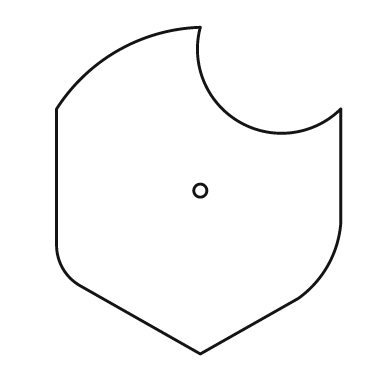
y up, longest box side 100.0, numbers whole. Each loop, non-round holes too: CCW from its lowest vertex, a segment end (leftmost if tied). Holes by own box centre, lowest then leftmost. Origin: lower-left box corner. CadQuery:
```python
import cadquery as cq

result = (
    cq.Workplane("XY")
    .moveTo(44.0, 0.0)
    .lineTo(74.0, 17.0)
    .threePointArc((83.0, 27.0), (87.0, 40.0))
    .lineTo(87.0, 75.0)
    .threePointArc((56.0, 71.0), (44.0, 100.0))
    .threePointArc((19.0, 93.0), (0.0, 75.0))
    .lineTo(0.0, 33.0)
    .threePointArc((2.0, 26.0), (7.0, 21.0))
    .close()
    .moveTo(44.0, 50.0)
    .circle(2.0)
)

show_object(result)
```